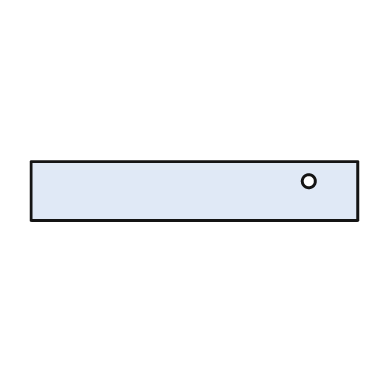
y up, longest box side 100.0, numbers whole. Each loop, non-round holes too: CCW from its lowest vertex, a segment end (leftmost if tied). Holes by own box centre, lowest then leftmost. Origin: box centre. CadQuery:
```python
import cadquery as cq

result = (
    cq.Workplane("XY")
    .moveTo(-50.0, -9.0)
    .lineTo(50.0, -9.0)
    .lineTo(50.0, 9.0)
    .lineTo(-50.0, 9.0)
    .close()
    .moveTo(35.0, 3.0)
    .circle(2.0)
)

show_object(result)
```